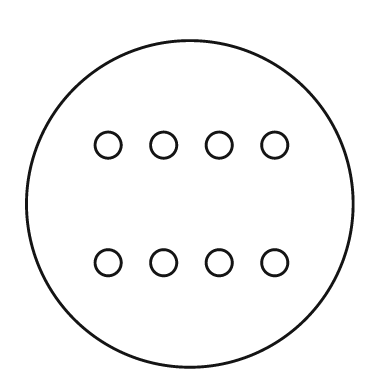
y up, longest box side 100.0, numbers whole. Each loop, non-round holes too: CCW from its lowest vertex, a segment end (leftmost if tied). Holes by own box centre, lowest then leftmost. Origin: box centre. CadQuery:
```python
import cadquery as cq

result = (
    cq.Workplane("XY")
    .moveTo(0.0, 0.0)
    .circle(50.0)
    .moveTo(-25.0, -18.0)
    .circle(4.0)
    .moveTo(-8.0, -18.0)
    .circle(4.0)
    .moveTo(9.0, -18.0)
    .circle(4.0)
    .moveTo(26.0, -18.0)
    .circle(4.0)
    .moveTo(-25.0, 18.0)
    .circle(4.0)
    .moveTo(-8.0, 18.0)
    .circle(4.0)
    .moveTo(9.0, 18.0)
    .circle(4.0)
    .moveTo(26.0, 18.0)
    .circle(4.0)
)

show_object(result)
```